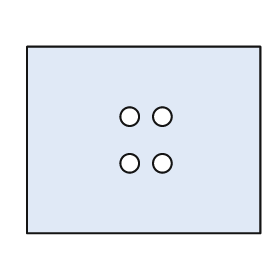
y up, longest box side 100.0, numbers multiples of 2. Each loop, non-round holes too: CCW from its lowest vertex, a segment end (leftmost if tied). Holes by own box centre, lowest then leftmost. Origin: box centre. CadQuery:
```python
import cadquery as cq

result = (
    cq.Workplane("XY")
    .moveTo(-50.0, -40.0)
    .lineTo(50.0, -40.0)
    .lineTo(50.0, 40.0)
    .lineTo(-50.0, 40.0)
    .close()
    .moveTo(-6.0, -10.0)
    .circle(4.0)
    .moveTo(8.0, -10.0)
    .circle(4.0)
    .moveTo(-6.0, 10.0)
    .circle(4.0)
    .moveTo(8.0, 10.0)
    .circle(4.0)
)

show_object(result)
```